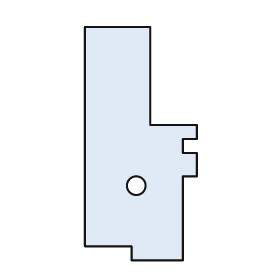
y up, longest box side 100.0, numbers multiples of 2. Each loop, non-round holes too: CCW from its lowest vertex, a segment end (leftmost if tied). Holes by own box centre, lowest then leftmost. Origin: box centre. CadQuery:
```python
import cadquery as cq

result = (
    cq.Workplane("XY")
    .moveTo(-4.0, -50.0)
    .lineTo(18.0, -50.0)
    .lineTo(18.0, -14.0)
    .lineTo(24.0, -14.0)
    .lineTo(24.0, -4.0)
    .lineTo(18.0, -4.0)
    .lineTo(18.0, 2.0)
    .lineTo(24.0, 2.0)
    .lineTo(24.0, 8.0)
    .lineTo(4.0, 8.0)
    .lineTo(4.0, 50.0)
    .lineTo(-24.0, 50.0)
    .lineTo(-24.0, -44.0)
    .lineTo(-4.0, -44.0)
    .close()
    .moveTo(-2.0, -18.0)
    .circle(4.0)
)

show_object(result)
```